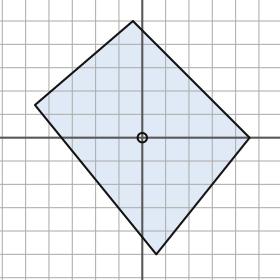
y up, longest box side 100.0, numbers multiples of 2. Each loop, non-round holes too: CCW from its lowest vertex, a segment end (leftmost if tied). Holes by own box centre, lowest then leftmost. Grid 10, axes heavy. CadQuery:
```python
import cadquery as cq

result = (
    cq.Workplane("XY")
    .moveTo(6.0, -50.0)
    .lineTo(46.0, 0.0)
    .lineTo(-4.0, 50.0)
    .lineTo(-46.0, 14.0)
    .close()
    .moveTo(0.0, 0.0)
    .circle(2.0)
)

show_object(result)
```